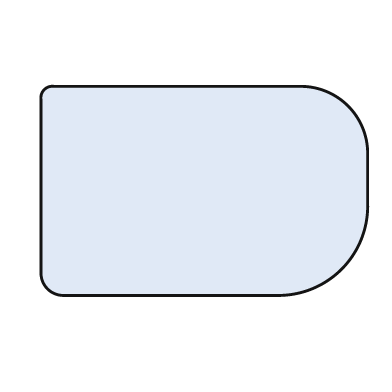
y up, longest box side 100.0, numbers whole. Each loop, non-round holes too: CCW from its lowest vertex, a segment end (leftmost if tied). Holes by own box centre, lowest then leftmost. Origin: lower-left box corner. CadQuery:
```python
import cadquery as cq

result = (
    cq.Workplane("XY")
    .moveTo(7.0, 0.0)
    .lineTo(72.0, 0.0)
    .threePointArc((92.0, 8.0), (100.0, 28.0))
    .lineTo(100.0, 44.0)
    .threePointArc((94.0, 58.0), (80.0, 64.0))
    .lineTo(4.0, 64.0)
    .threePointArc((1.0, 63.0), (0.0, 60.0))
    .lineTo(0.0, 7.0)
    .threePointArc((2.0, 2.0), (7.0, 0.0))
    .close()
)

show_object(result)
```